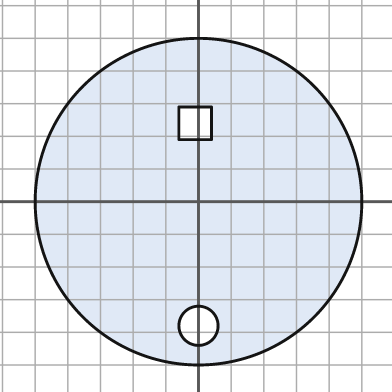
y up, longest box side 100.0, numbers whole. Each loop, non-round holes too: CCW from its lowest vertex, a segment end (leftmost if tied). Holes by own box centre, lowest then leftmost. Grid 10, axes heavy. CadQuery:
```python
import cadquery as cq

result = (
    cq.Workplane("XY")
    .moveTo(0.0, 0.0)
    .circle(50.0)
    .moveTo(0.0, -38.0)
    .circle(6.0)
    .moveTo(-6.0, 19.0)
    .lineTo(4.0, 19.0)
    .lineTo(4.0, 29.0)
    .lineTo(-6.0, 29.0)
    .close()
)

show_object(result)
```